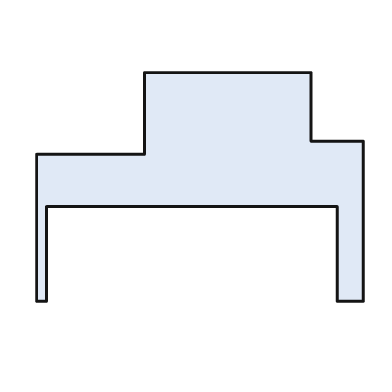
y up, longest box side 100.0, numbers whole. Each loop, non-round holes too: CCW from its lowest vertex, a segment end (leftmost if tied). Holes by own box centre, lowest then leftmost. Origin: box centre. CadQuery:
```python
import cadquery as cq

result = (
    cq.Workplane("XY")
    .moveTo(-50.0, -35.0)
    .lineTo(-47.0, -35.0)
    .lineTo(-47.0, -6.0)
    .lineTo(42.0, -6.0)
    .lineTo(42.0, -35.0)
    .lineTo(50.0, -35.0)
    .lineTo(50.0, 14.0)
    .lineTo(34.0, 14.0)
    .lineTo(34.0, 35.0)
    .lineTo(-17.0, 35.0)
    .lineTo(-17.0, 10.0)
    .lineTo(-50.0, 10.0)
    .close()
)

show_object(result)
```